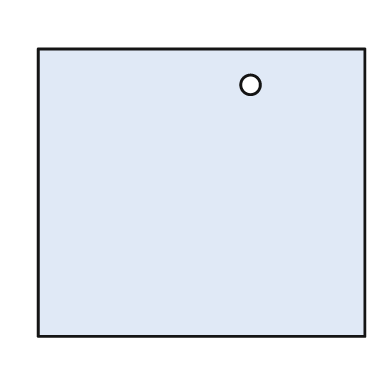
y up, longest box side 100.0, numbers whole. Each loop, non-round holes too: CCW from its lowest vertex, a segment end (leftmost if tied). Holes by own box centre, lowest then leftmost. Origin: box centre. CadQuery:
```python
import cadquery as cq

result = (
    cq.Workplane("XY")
    .moveTo(-50.0, -44.0)
    .lineTo(50.0, -44.0)
    .lineTo(50.0, 44.0)
    .lineTo(-50.0, 44.0)
    .close()
    .moveTo(15.0, 33.0)
    .circle(3.0)
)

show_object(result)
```